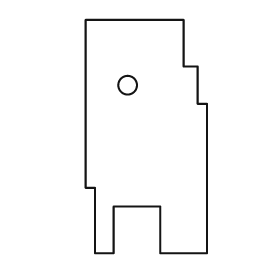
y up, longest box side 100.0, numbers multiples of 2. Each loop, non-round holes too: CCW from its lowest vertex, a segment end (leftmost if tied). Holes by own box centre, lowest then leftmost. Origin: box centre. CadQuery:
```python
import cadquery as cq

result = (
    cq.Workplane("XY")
    .moveTo(-22.0, -50.0)
    .lineTo(-14.0, -50.0)
    .lineTo(-14.0, -30.0)
    .lineTo(6.0, -30.0)
    .lineTo(6.0, -50.0)
    .lineTo(26.0, -50.0)
    .lineTo(26.0, 14.0)
    .lineTo(22.0, 14.0)
    .lineTo(22.0, 30.0)
    .lineTo(16.0, 30.0)
    .lineTo(16.0, 50.0)
    .lineTo(-26.0, 50.0)
    .lineTo(-26.0, -22.0)
    .lineTo(-22.0, -22.0)
    .close()
    .moveTo(-8.0, 22.0)
    .circle(4.0)
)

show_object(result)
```